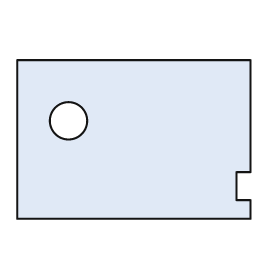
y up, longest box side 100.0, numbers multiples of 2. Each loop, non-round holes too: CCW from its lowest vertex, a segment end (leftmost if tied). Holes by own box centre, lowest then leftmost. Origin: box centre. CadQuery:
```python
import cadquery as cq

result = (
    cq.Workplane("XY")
    .moveTo(-50.0, -34.0)
    .lineTo(50.0, -34.0)
    .lineTo(50.0, -26.0)
    .lineTo(44.0, -26.0)
    .lineTo(44.0, -14.0)
    .lineTo(50.0, -14.0)
    .lineTo(50.0, 34.0)
    .lineTo(-50.0, 34.0)
    .close()
    .moveTo(-28.0, 8.0)
    .circle(8.0)
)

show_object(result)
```